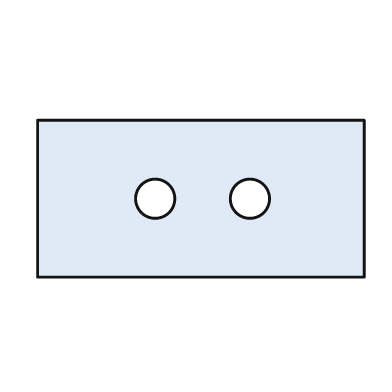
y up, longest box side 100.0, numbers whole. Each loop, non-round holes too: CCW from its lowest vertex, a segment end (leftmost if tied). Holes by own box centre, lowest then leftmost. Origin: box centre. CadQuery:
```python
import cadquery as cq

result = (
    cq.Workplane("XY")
    .moveTo(-50.0, -24.0)
    .lineTo(50.0, -24.0)
    .lineTo(50.0, 24.0)
    .lineTo(-50.0, 24.0)
    .close()
    .moveTo(-14.0, 0.0)
    .circle(6.0)
    .moveTo(15.0, 0.0)
    .circle(6.0)
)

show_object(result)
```